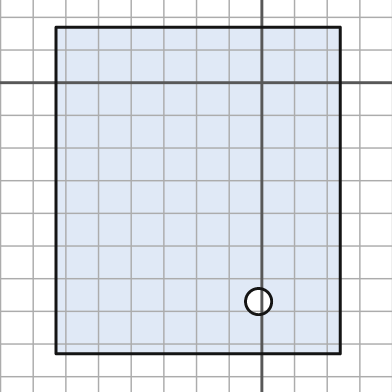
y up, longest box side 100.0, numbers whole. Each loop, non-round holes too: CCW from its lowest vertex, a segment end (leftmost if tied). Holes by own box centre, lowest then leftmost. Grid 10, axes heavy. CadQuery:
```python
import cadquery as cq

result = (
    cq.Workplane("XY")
    .moveTo(-63.0, -83.0)
    .lineTo(24.0, -83.0)
    .lineTo(24.0, 17.0)
    .lineTo(-63.0, 17.0)
    .close()
    .moveTo(-1.0, -67.0)
    .circle(4.0)
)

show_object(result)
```